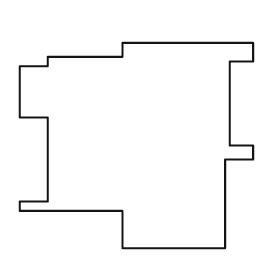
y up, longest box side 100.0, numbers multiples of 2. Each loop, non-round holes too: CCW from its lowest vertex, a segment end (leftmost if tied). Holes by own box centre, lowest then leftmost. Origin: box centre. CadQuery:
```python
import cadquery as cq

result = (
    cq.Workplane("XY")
    .moveTo(-6.0, -44.0)
    .lineTo(38.0, -44.0)
    .lineTo(38.0, -6.0)
    .lineTo(50.0, -6.0)
    .lineTo(50.0, 0.0)
    .lineTo(40.0, 0.0)
    .lineTo(40.0, 36.0)
    .lineTo(50.0, 36.0)
    .lineTo(50.0, 44.0)
    .lineTo(-6.0, 44.0)
    .lineTo(-6.0, 38.0)
    .lineTo(-38.0, 38.0)
    .lineTo(-38.0, 34.0)
    .lineTo(-50.0, 34.0)
    .lineTo(-50.0, 12.0)
    .lineTo(-38.0, 12.0)
    .lineTo(-38.0, -24.0)
    .lineTo(-50.0, -24.0)
    .lineTo(-50.0, -28.0)
    .lineTo(-6.0, -28.0)
    .close()
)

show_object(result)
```